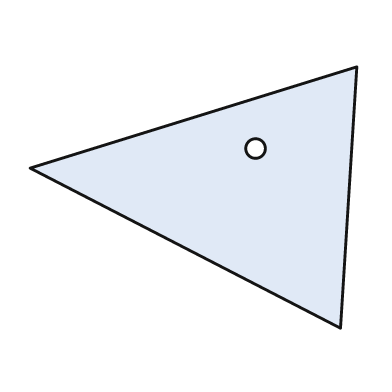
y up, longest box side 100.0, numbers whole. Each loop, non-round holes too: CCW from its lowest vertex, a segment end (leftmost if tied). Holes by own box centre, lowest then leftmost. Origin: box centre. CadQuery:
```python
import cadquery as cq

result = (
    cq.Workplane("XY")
    .moveTo(45.0, -40.0)
    .lineTo(50.0, 40.0)
    .lineTo(-50.0, 9.0)
    .close()
    .moveTo(19.0, 15.0)
    .circle(3.0)
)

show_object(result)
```